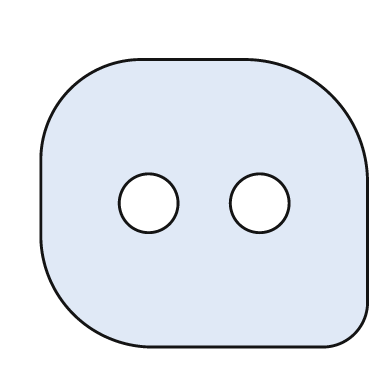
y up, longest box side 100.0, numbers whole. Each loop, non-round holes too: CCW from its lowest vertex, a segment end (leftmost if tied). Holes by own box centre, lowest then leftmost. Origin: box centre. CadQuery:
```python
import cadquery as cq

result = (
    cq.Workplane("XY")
    .moveTo(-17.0, -44.0)
    .lineTo(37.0, -44.0)
    .threePointArc((46.0, -40.0), (50.0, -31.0))
    .lineTo(50.0, 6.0)
    .threePointArc((39.0, 33.0), (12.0, 44.0))
    .lineTo(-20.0, 44.0)
    .threePointArc((-41.0, 35.0), (-50.0, 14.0))
    .lineTo(-50.0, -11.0)
    .threePointArc((-40.0, -34.0), (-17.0, -44.0))
    .close()
    .moveTo(-17.0, 0.0)
    .circle(9.0)
    .moveTo(17.0, 0.0)
    .circle(9.0)
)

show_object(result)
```